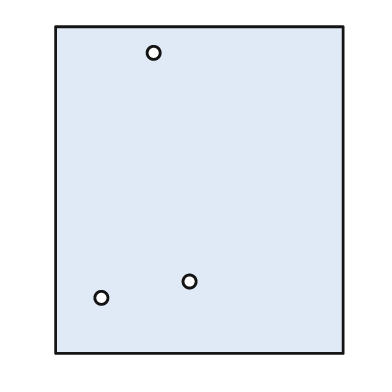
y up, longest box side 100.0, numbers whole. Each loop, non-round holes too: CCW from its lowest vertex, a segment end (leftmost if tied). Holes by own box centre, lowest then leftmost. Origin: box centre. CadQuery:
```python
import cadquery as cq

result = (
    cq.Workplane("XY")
    .moveTo(-44.0, -50.0)
    .lineTo(44.0, -50.0)
    .lineTo(44.0, 50.0)
    .lineTo(-44.0, 50.0)
    .close()
    .moveTo(-30.0, -33.0)
    .circle(2.0)
    .moveTo(-3.0, -28.0)
    .circle(2.0)
    .moveTo(-14.0, 42.0)
    .circle(2.0)
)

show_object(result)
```